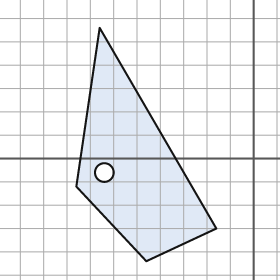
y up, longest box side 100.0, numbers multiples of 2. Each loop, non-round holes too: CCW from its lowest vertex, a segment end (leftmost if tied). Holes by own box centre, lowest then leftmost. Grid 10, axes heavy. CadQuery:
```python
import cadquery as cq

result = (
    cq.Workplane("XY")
    .moveTo(-46.0, -44.0)
    .lineTo(-16.0, -30.0)
    .lineTo(-66.0, 56.0)
    .lineTo(-76.0, -12.0)
    .close()
    .moveTo(-64.0, -6.0)
    .circle(4.0)
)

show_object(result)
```